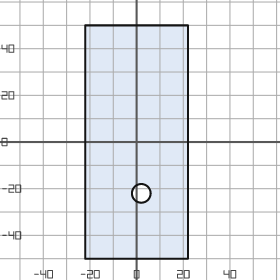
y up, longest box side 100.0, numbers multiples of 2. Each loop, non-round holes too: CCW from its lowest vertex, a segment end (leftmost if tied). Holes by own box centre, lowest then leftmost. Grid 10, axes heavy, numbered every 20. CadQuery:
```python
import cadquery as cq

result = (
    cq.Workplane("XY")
    .moveTo(-22.0, -50.0)
    .lineTo(22.0, -50.0)
    .lineTo(22.0, 50.0)
    .lineTo(-22.0, 50.0)
    .close()
    .moveTo(2.0, -22.0)
    .circle(4.0)
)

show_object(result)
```